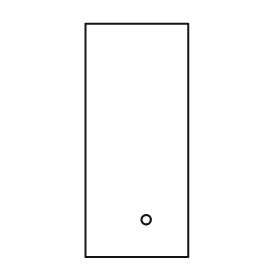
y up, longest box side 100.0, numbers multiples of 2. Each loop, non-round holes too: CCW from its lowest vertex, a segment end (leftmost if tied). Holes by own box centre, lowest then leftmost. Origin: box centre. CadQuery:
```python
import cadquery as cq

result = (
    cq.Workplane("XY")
    .moveTo(-22.0, -50.0)
    .lineTo(22.0, -50.0)
    .lineTo(22.0, 50.0)
    .lineTo(-22.0, 50.0)
    .close()
    .moveTo(4.0, -34.0)
    .circle(2.0)
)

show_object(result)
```